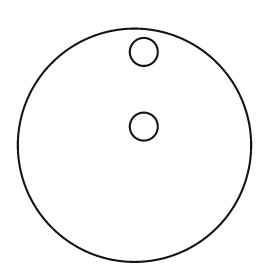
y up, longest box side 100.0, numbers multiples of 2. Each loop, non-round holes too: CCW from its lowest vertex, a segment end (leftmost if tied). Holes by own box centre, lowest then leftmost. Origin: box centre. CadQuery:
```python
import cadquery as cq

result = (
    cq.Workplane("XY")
    .moveTo(0.0, 0.0)
    .circle(50.0)
    .moveTo(4.0, 8.0)
    .circle(6.0)
    .moveTo(4.0, 40.0)
    .circle(6.0)
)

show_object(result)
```